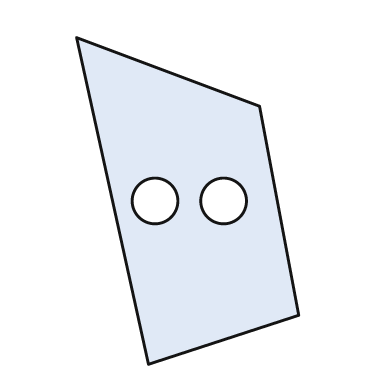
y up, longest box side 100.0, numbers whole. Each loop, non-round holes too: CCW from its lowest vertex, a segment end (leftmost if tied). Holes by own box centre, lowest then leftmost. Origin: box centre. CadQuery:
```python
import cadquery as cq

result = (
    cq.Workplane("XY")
    .moveTo(-12.0, -50.0)
    .lineTo(34.0, -35.0)
    .lineTo(22.0, 29.0)
    .lineTo(-34.0, 50.0)
    .close()
    .moveTo(-10.0, 0.0)
    .circle(7.0)
    .moveTo(11.0, 0.0)
    .circle(7.0)
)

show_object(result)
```